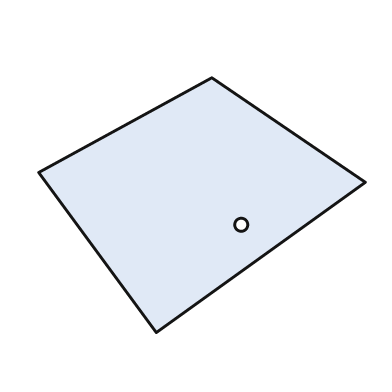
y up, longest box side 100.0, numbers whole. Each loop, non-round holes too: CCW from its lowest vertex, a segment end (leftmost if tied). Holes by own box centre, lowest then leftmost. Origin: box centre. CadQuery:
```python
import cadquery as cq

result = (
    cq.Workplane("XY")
    .moveTo(-14.0, -39.0)
    .lineTo(50.0, 7.0)
    .lineTo(3.0, 39.0)
    .lineTo(-50.0, 10.0)
    .close()
    .moveTo(12.0, -6.0)
    .circle(2.0)
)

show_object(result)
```